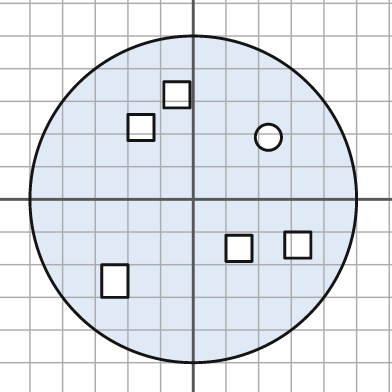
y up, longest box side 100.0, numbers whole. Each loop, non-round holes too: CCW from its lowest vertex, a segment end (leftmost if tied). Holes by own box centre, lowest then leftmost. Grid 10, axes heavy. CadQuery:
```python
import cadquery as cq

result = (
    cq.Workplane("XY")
    .moveTo(0.0, 0.0)
    .circle(50.0)
    .moveTo(-28.0, -30.0)
    .lineTo(-20.0, -30.0)
    .lineTo(-20.0, -20.0)
    .lineTo(-28.0, -20.0)
    .close()
    .moveTo(10.0, -19.0)
    .lineTo(18.0, -19.0)
    .lineTo(18.0, -11.0)
    .lineTo(10.0, -11.0)
    .close()
    .moveTo(28.0, -18.0)
    .lineTo(36.0, -18.0)
    .lineTo(36.0, -10.0)
    .lineTo(28.0, -10.0)
    .close()
    .moveTo(23.0, 19.0)
    .circle(4.0)
    .moveTo(-20.0, 18.0)
    .lineTo(-12.0, 18.0)
    .lineTo(-12.0, 26.0)
    .lineTo(-20.0, 26.0)
    .close()
    .moveTo(-9.0, 28.0)
    .lineTo(-1.0, 28.0)
    .lineTo(-1.0, 36.0)
    .lineTo(-9.0, 36.0)
    .close()
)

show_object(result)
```